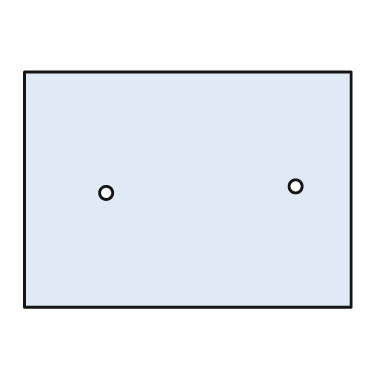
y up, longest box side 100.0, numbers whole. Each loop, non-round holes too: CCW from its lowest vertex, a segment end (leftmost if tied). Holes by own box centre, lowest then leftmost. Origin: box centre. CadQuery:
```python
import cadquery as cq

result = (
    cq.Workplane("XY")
    .moveTo(-50.0, -36.0)
    .lineTo(50.0, -36.0)
    .lineTo(50.0, 36.0)
    .lineTo(-50.0, 36.0)
    .close()
    .moveTo(-25.0, -1.0)
    .circle(2.0)
    .moveTo(33.0, 1.0)
    .circle(2.0)
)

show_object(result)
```